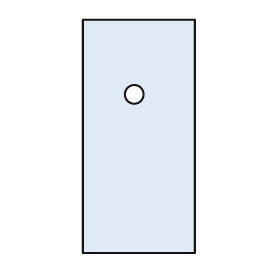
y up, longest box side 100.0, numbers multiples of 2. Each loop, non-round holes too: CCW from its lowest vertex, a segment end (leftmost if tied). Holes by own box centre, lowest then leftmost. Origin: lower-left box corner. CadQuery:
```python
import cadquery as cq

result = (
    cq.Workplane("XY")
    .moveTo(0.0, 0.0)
    .lineTo(48.0, 0.0)
    .lineTo(48.0, 100.0)
    .lineTo(0.0, 100.0)
    .close()
    .moveTo(22.0, 68.0)
    .circle(4.0)
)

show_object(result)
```